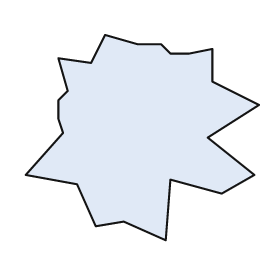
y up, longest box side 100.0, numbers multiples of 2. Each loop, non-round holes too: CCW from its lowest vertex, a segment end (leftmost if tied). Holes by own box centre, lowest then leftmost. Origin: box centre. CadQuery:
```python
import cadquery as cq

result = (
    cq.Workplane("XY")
    .moveTo(10.0, -44.0)
    .lineTo(12.0, -18.0)
    .lineTo(34.0, -24.0)
    .lineTo(48.0, -16.0)
    .lineTo(28.0, 0.0)
    .lineTo(50.0, 14.0)
    .lineTo(30.0, 24.0)
    .lineTo(30.0, 38.0)
    .lineTo(20.0, 36.0)
    .lineTo(12.0, 36.0)
    .lineTo(8.0, 40.0)
    .lineTo(-2.0, 40.0)
    .lineTo(-16.0, 44.0)
    .lineTo(-22.0, 32.0)
    .lineTo(-36.0, 34.0)
    .lineTo(-32.0, 20.0)
    .lineTo(-36.0, 16.0)
    .lineTo(-36.0, 8.0)
    .lineTo(-34.0, 2.0)
    .lineTo(-50.0, -16.0)
    .lineTo(-28.0, -20.0)
    .lineTo(-20.0, -38.0)
    .lineTo(-8.0, -36.0)
    .close()
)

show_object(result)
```